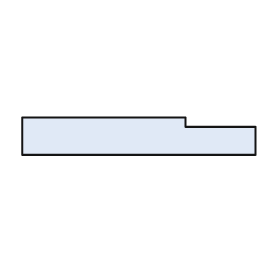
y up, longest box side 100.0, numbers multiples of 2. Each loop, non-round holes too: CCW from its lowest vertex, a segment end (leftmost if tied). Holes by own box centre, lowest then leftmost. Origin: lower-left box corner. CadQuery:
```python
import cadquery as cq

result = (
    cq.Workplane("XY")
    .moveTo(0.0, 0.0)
    .lineTo(100.0, 0.0)
    .lineTo(100.0, 12.0)
    .lineTo(70.0, 12.0)
    .lineTo(70.0, 16.0)
    .lineTo(0.0, 16.0)
    .close()
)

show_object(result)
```